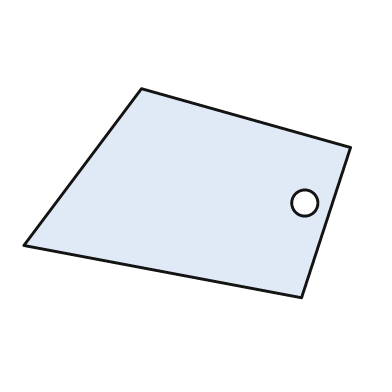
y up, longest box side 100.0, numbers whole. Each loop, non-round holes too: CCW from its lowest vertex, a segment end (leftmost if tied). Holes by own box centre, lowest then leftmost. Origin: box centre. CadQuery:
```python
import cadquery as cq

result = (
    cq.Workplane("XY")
    .moveTo(35.0, -32.0)
    .lineTo(50.0, 14.0)
    .lineTo(-14.0, 32.0)
    .lineTo(-50.0, -16.0)
    .close()
    .moveTo(36.0, -3.0)
    .circle(4.0)
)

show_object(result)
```